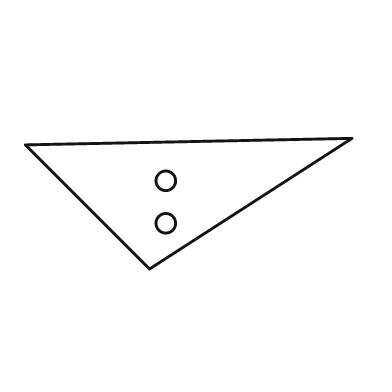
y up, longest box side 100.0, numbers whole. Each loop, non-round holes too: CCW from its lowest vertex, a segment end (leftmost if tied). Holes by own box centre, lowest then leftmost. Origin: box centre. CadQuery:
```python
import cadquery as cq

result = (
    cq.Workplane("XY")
    .moveTo(-12.0, -20.0)
    .lineTo(50.0, 20.0)
    .lineTo(-50.0, 18.0)
    .close()
    .moveTo(-7.0, -6.0)
    .circle(3.0)
    .moveTo(-7.0, 7.0)
    .circle(3.0)
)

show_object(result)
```